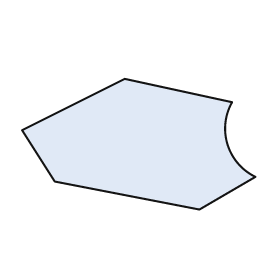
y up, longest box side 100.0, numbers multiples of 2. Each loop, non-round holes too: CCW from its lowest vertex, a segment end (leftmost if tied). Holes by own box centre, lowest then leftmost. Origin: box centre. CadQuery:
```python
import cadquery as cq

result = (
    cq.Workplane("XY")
    .moveTo(26.0, -28.0)
    .lineTo(50.0, -14.0)
    .threePointArc((38.0, 0.0), (40.0, 18.0))
    .lineTo(-6.0, 28.0)
    .lineTo(-50.0, 6.0)
    .lineTo(-36.0, -16.0)
    .close()
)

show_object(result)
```